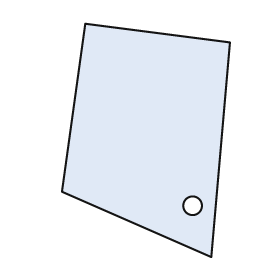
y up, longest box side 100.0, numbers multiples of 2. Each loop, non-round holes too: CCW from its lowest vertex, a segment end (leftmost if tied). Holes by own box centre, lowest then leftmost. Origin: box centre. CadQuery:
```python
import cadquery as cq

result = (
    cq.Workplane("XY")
    .moveTo(28.0, -50.0)
    .lineTo(36.0, 42.0)
    .lineTo(-26.0, 50.0)
    .lineTo(-36.0, -22.0)
    .close()
    .moveTo(20.0, -28.0)
    .circle(4.0)
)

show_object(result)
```